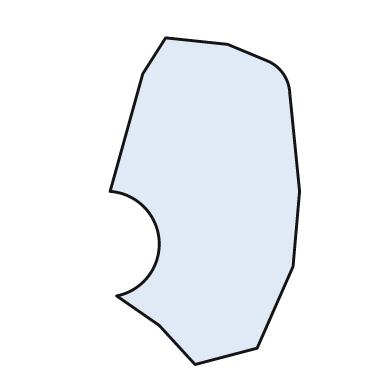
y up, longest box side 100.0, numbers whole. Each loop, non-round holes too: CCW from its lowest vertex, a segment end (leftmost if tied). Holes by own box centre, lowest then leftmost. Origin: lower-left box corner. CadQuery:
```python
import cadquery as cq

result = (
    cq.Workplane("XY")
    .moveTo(26.0, 0.0)
    .lineTo(45.0, 5.0)
    .lineTo(56.0, 30.0)
    .lineTo(58.0, 53.0)
    .lineTo(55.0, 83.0)
    .threePointArc((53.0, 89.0), (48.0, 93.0))
    .lineTo(36.0, 98.0)
    .lineTo(17.0, 100.0)
    .lineTo(10.0, 89.0)
    .lineTo(0.0, 53.0)
    .threePointArc((15.0, 38.0), (2.0, 21.0))
    .lineTo(15.0, 12.0)
    .close()
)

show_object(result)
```